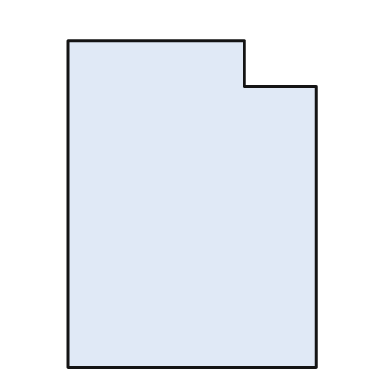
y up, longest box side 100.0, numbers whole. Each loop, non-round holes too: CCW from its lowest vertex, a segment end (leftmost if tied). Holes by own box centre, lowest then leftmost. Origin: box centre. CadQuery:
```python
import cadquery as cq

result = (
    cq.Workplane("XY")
    .moveTo(-38.0, -50.0)
    .lineTo(38.0, -50.0)
    .lineTo(38.0, 36.0)
    .lineTo(16.0, 36.0)
    .lineTo(16.0, 50.0)
    .lineTo(-38.0, 50.0)
    .close()
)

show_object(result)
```